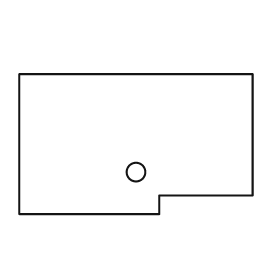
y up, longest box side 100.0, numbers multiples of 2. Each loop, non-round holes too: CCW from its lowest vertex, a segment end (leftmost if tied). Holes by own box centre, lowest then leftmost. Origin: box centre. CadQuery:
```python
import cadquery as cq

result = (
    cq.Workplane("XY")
    .moveTo(-50.0, -30.0)
    .lineTo(10.0, -30.0)
    .lineTo(10.0, -22.0)
    .lineTo(50.0, -22.0)
    .lineTo(50.0, 30.0)
    .lineTo(-50.0, 30.0)
    .close()
    .moveTo(0.0, -12.0)
    .circle(4.0)
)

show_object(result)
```